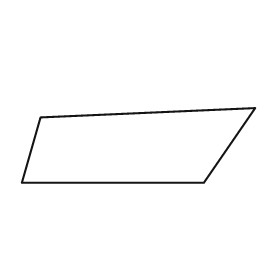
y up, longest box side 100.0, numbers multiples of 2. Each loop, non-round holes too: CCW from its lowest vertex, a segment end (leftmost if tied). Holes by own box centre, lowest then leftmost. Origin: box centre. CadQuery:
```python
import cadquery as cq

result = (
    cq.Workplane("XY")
    .moveTo(-50.0, -16.0)
    .lineTo(28.0, -16.0)
    .lineTo(50.0, 16.0)
    .lineTo(-42.0, 12.0)
    .close()
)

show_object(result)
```